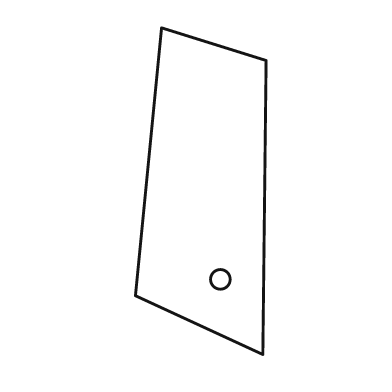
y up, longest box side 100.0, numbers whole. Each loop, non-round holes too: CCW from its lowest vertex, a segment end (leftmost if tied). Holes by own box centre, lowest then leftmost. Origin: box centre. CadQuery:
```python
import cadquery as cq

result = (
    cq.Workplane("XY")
    .moveTo(19.0, -50.0)
    .lineTo(20.0, 40.0)
    .lineTo(-12.0, 50.0)
    .lineTo(-20.0, -32.0)
    .close()
    .moveTo(6.0, -27.0)
    .circle(3.0)
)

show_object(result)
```